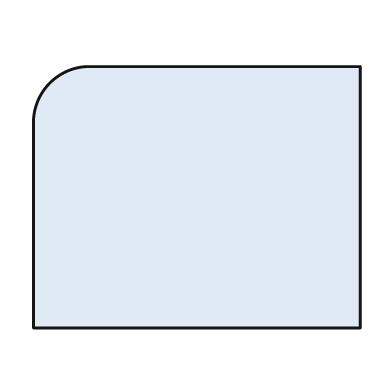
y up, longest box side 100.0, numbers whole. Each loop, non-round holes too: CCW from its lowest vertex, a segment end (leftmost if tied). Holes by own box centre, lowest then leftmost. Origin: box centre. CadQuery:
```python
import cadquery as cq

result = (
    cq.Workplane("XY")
    .moveTo(-50.0, -40.0)
    .lineTo(50.0, -40.0)
    .lineTo(50.0, 40.0)
    .lineTo(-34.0, 40.0)
    .threePointArc((-45.0, 35.0), (-50.0, 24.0))
    .close()
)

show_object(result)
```